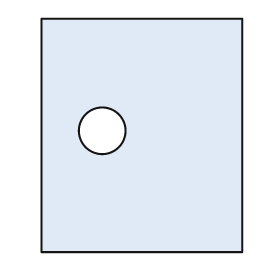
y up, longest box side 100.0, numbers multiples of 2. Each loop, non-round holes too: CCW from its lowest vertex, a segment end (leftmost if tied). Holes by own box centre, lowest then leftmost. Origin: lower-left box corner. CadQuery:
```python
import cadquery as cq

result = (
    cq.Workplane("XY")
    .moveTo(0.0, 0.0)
    .lineTo(86.0, 0.0)
    .lineTo(86.0, 100.0)
    .lineTo(0.0, 100.0)
    .close()
    .moveTo(26.0, 52.0)
    .circle(10.0)
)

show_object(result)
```